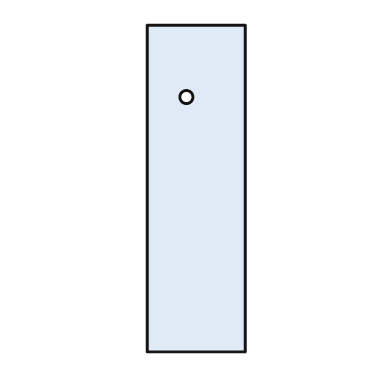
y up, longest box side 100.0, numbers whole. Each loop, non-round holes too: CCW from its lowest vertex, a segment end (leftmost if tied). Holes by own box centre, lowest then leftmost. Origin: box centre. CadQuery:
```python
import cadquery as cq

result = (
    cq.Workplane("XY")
    .moveTo(-15.0, -50.0)
    .lineTo(15.0, -50.0)
    .lineTo(15.0, 50.0)
    .lineTo(-15.0, 50.0)
    .close()
    .moveTo(-3.0, 28.0)
    .circle(2.0)
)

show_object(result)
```